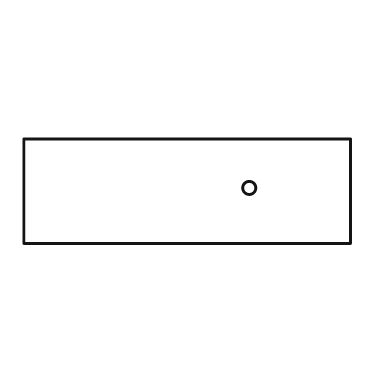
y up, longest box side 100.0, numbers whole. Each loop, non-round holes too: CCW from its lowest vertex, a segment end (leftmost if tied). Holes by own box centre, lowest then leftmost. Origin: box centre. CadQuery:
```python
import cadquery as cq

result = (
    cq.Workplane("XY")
    .moveTo(-50.0, -16.0)
    .lineTo(50.0, -16.0)
    .lineTo(50.0, 16.0)
    .lineTo(-50.0, 16.0)
    .close()
    .moveTo(19.0, 1.0)
    .circle(2.0)
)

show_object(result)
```